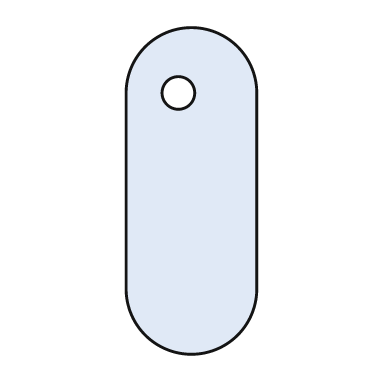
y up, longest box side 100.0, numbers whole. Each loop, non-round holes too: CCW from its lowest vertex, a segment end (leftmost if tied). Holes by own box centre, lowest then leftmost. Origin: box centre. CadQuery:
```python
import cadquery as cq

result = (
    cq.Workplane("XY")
    .moveTo(-20.0, -30.0)
    .threePointArc((0.0, -50.0), (20.0, -30.0))
    .lineTo(20.0, 30.0)
    .threePointArc((0.0, 50.0), (-20.0, 30.0))
    .close()
    .moveTo(-4.0, 30.0)
    .circle(5.0)
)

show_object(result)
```